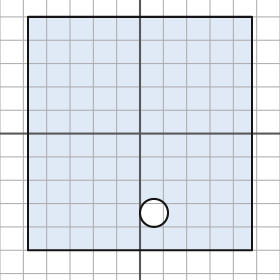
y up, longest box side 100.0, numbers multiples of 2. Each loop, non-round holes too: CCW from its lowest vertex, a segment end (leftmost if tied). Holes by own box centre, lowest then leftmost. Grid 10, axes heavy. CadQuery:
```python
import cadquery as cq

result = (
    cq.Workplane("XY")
    .moveTo(-48.0, -50.0)
    .lineTo(48.0, -50.0)
    .lineTo(48.0, 50.0)
    .lineTo(-48.0, 50.0)
    .close()
    .moveTo(6.0, -34.0)
    .circle(6.0)
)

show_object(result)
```